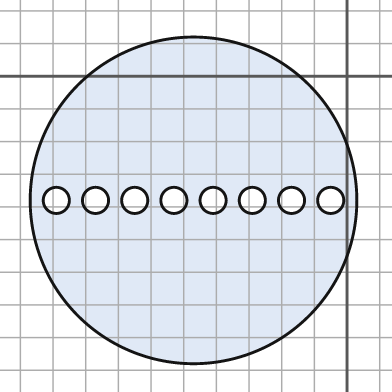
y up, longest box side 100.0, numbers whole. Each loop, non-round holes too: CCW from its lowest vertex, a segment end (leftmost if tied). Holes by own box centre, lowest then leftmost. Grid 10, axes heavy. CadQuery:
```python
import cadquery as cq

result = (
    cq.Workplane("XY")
    .moveTo(-47.0, -38.0)
    .circle(50.0)
    .moveTo(-89.0, -38.0)
    .circle(4.0)
    .moveTo(-77.0, -38.0)
    .circle(4.0)
    .moveTo(-65.0, -38.0)
    .circle(4.0)
    .moveTo(-53.0, -38.0)
    .circle(4.0)
    .moveTo(-41.0, -38.0)
    .circle(4.0)
    .moveTo(-29.0, -38.0)
    .circle(4.0)
    .moveTo(-17.0, -38.0)
    .circle(4.0)
    .moveTo(-5.0, -38.0)
    .circle(4.0)
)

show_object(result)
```